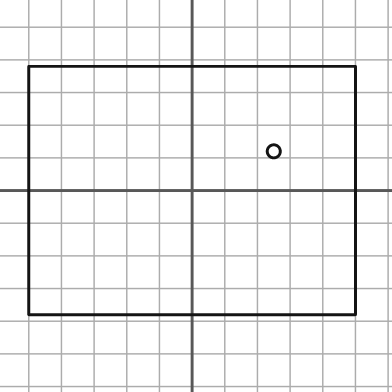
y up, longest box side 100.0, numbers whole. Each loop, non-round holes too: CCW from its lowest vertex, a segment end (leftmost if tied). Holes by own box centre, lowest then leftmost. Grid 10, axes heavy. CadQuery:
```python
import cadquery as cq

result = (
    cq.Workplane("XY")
    .moveTo(-50.0, -38.0)
    .lineTo(50.0, -38.0)
    .lineTo(50.0, 38.0)
    .lineTo(-50.0, 38.0)
    .close()
    .moveTo(25.0, 12.0)
    .circle(2.0)
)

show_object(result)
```